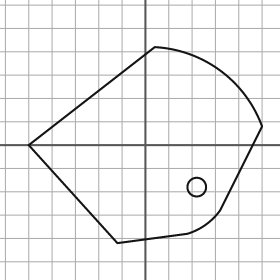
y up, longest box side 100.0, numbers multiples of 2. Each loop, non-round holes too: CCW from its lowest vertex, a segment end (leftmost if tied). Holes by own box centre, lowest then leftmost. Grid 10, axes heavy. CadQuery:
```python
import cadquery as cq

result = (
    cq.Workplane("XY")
    .moveTo(-12.0, -42.0)
    .lineTo(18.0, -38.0)
    .threePointArc((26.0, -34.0), (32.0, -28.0))
    .lineTo(50.0, 8.0)
    .threePointArc((32.0, 32.0), (4.0, 42.0))
    .lineTo(-50.0, 0.0)
    .close()
    .moveTo(22.0, -18.0)
    .circle(4.0)
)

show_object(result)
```